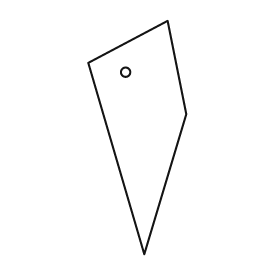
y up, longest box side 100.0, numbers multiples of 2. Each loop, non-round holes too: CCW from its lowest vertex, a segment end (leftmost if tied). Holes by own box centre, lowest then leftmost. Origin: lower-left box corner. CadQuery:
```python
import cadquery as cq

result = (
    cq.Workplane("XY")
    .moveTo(24.0, 0.0)
    .lineTo(42.0, 60.0)
    .lineTo(34.0, 100.0)
    .lineTo(0.0, 82.0)
    .close()
    .moveTo(16.0, 78.0)
    .circle(2.0)
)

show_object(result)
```